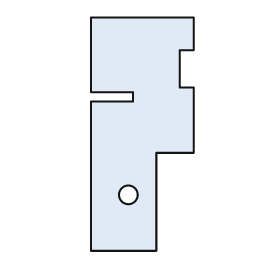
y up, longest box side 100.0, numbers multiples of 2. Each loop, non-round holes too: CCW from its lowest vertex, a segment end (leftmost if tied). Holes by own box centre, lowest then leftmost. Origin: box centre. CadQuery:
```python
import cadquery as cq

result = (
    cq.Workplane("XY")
    .moveTo(-22.0, -50.0)
    .lineTo(6.0, -50.0)
    .lineTo(6.0, -8.0)
    .lineTo(22.0, -8.0)
    .lineTo(22.0, 20.0)
    .lineTo(16.0, 20.0)
    .lineTo(16.0, 36.0)
    .lineTo(22.0, 36.0)
    .lineTo(22.0, 50.0)
    .lineTo(-22.0, 50.0)
    .lineTo(-22.0, 18.0)
    .lineTo(-4.0, 18.0)
    .lineTo(-4.0, 14.0)
    .lineTo(-22.0, 14.0)
    .close()
    .moveTo(-6.0, -26.0)
    .circle(4.0)
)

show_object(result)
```